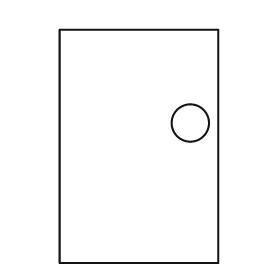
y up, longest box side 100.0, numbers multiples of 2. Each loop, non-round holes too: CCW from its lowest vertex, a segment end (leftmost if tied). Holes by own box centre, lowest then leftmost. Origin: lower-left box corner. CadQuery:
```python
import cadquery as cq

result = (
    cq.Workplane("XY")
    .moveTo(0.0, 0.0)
    .lineTo(68.0, 0.0)
    .lineTo(68.0, 100.0)
    .lineTo(0.0, 100.0)
    .close()
    .moveTo(56.0, 60.0)
    .circle(8.0)
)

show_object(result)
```